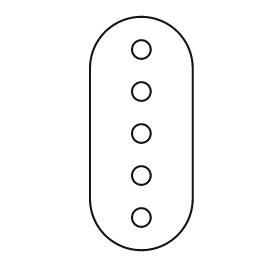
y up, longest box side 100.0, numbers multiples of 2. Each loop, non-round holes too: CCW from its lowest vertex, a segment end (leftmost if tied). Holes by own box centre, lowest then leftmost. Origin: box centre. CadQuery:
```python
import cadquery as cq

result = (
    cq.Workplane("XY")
    .moveTo(-22.0, -28.0)
    .threePointArc((0.0, -50.0), (22.0, -28.0))
    .lineTo(22.0, 28.0)
    .threePointArc((0.0, 50.0), (-22.0, 28.0))
    .close()
    .moveTo(0.0, -36.0)
    .circle(4.0)
    .moveTo(0.0, -18.0)
    .circle(4.0)
    .moveTo(0.0, 0.0)
    .circle(4.0)
    .moveTo(0.0, 18.0)
    .circle(4.0)
    .moveTo(0.0, 36.0)
    .circle(4.0)
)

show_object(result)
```